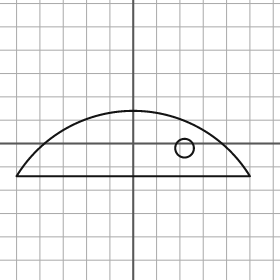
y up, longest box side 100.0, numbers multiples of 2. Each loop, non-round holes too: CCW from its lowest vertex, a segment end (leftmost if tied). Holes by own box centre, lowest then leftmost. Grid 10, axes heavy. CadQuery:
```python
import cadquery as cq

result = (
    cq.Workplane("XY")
    .moveTo(-50.0, -14.0)
    .lineTo(50.0, -14.0)
    .threePointArc((0.0, 14.0), (-50.0, -14.0))
    .close()
    .moveTo(22.0, -2.0)
    .circle(4.0)
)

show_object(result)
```